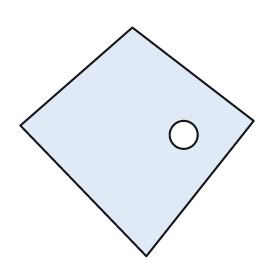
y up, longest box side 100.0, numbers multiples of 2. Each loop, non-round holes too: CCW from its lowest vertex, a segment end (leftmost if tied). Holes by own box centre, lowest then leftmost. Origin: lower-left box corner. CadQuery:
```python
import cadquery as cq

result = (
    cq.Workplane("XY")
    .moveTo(54.0, 0.0)
    .lineTo(100.0, 58.0)
    .lineTo(48.0, 98.0)
    .lineTo(0.0, 56.0)
    .close()
    .moveTo(70.0, 52.0)
    .circle(6.0)
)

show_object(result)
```